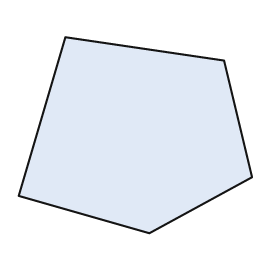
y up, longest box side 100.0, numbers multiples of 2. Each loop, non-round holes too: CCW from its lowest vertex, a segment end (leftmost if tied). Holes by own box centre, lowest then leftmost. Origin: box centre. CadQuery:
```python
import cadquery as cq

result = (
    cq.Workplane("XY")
    .moveTo(6.0, -42.0)
    .lineTo(50.0, -18.0)
    .lineTo(38.0, 32.0)
    .lineTo(-30.0, 42.0)
    .lineTo(-50.0, -26.0)
    .close()
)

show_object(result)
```